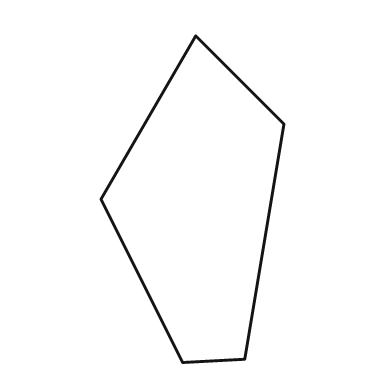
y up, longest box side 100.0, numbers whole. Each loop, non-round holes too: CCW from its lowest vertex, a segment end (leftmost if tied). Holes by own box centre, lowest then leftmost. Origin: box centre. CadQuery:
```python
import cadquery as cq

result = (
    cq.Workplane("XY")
    .moveTo(-3.0, -50.0)
    .lineTo(16.0, -49.0)
    .lineTo(28.0, 23.0)
    .lineTo(1.0, 50.0)
    .lineTo(-28.0, 0.0)
    .close()
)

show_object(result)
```